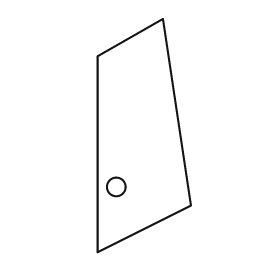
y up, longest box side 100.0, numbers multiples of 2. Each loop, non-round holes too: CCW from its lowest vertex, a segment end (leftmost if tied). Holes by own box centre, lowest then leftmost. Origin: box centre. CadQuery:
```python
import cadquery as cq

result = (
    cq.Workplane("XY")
    .moveTo(-20.0, -50.0)
    .lineTo(20.0, -30.0)
    .lineTo(8.0, 50.0)
    .lineTo(-20.0, 34.0)
    .close()
    .moveTo(-12.0, -22.0)
    .circle(4.0)
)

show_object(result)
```